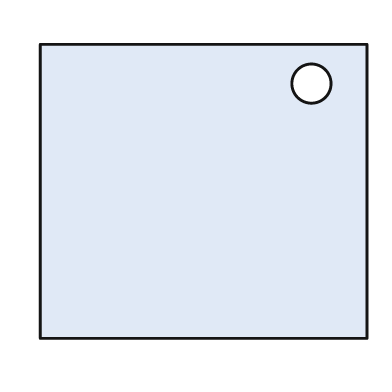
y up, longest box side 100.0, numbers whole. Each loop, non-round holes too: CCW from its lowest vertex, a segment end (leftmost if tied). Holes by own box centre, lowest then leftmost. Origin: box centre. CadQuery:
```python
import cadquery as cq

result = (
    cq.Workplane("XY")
    .moveTo(-50.0, -45.0)
    .lineTo(50.0, -45.0)
    .lineTo(50.0, 45.0)
    .lineTo(-50.0, 45.0)
    .close()
    .moveTo(33.0, 33.0)
    .circle(6.0)
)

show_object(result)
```